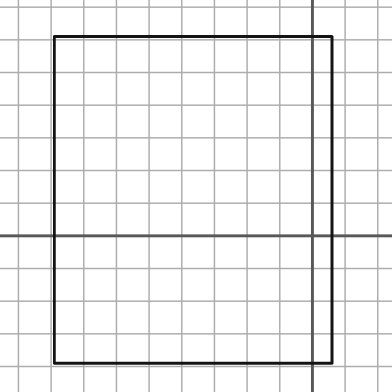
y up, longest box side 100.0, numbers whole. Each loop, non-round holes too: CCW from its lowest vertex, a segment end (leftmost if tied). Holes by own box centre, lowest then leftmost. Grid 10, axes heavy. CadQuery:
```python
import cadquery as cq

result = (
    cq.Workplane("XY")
    .moveTo(-79.0, -39.0)
    .lineTo(6.0, -39.0)
    .lineTo(6.0, 61.0)
    .lineTo(-79.0, 61.0)
    .close()
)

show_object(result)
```